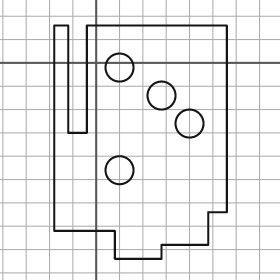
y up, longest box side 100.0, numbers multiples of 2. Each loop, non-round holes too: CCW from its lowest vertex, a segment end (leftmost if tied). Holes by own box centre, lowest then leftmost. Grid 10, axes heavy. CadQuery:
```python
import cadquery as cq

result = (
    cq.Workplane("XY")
    .moveTo(8.0, -84.0)
    .lineTo(28.0, -84.0)
    .lineTo(28.0, -78.0)
    .lineTo(48.0, -78.0)
    .lineTo(48.0, -64.0)
    .lineTo(56.0, -64.0)
    .lineTo(56.0, 16.0)
    .lineTo(-4.0, 16.0)
    .lineTo(-4.0, -30.0)
    .lineTo(-12.0, -30.0)
    .lineTo(-12.0, 16.0)
    .lineTo(-18.0, 16.0)
    .lineTo(-18.0, -72.0)
    .lineTo(8.0, -72.0)
    .close()
    .moveTo(10.0, -46.0)
    .circle(6.0)
    .moveTo(40.0, -26.0)
    .circle(6.0)
    .moveTo(28.0, -14.0)
    .circle(6.0)
    .moveTo(10.0, -2.0)
    .circle(6.0)
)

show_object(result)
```